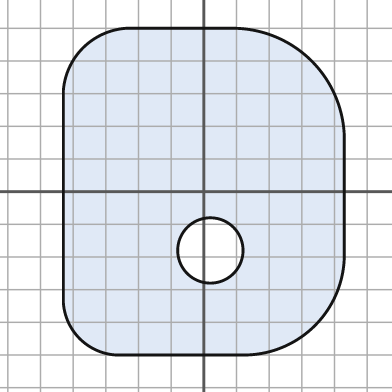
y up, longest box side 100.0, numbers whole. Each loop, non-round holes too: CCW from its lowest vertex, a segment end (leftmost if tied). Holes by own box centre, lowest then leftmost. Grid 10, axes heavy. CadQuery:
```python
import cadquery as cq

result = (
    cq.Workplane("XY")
    .moveTo(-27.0, -50.0)
    .lineTo(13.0, -50.0)
    .threePointArc((34.0, -41.0), (43.0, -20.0))
    .lineTo(43.0, 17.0)
    .threePointArc((33.0, 40.0), (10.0, 50.0))
    .lineTo(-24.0, 50.0)
    .threePointArc((-37.0, 44.0), (-43.0, 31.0))
    .lineTo(-43.0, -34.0)
    .threePointArc((-38.0, -45.0), (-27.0, -50.0))
    .close()
    .moveTo(2.0, -18.0)
    .circle(10.0)
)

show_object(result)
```